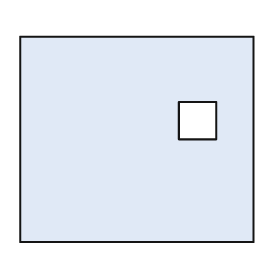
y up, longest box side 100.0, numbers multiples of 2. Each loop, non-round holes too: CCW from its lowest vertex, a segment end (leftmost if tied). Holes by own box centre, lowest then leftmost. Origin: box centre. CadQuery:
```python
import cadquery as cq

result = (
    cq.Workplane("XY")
    .moveTo(-50.0, -44.0)
    .lineTo(50.0, -44.0)
    .lineTo(50.0, 44.0)
    .lineTo(-50.0, 44.0)
    .close()
    .moveTo(18.0, 0.0)
    .lineTo(34.0, 0.0)
    .lineTo(34.0, 16.0)
    .lineTo(18.0, 16.0)
    .close()
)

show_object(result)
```